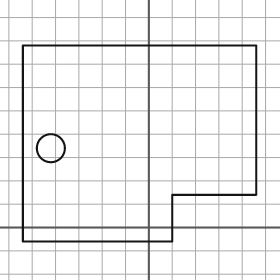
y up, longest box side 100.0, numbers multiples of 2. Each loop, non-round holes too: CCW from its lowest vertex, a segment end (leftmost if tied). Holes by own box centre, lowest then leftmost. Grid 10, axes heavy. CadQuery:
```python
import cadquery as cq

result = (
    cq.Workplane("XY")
    .moveTo(-54.0, -6.0)
    .lineTo(10.0, -6.0)
    .lineTo(10.0, 14.0)
    .lineTo(46.0, 14.0)
    .lineTo(46.0, 78.0)
    .lineTo(-54.0, 78.0)
    .close()
    .moveTo(-42.0, 34.0)
    .circle(6.0)
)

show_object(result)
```